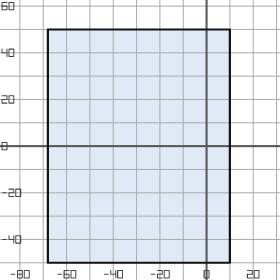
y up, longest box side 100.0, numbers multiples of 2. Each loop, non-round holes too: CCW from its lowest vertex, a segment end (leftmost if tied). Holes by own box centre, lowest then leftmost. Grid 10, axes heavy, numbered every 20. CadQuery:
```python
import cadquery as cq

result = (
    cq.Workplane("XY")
    .moveTo(-68.0, -50.0)
    .lineTo(10.0, -50.0)
    .lineTo(10.0, 50.0)
    .lineTo(-68.0, 50.0)
    .close()
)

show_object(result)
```